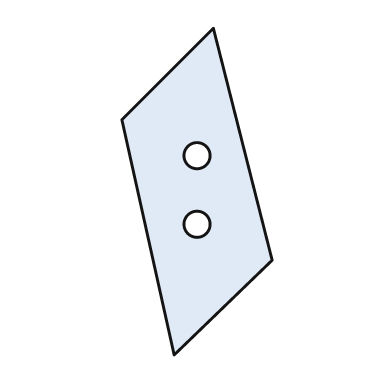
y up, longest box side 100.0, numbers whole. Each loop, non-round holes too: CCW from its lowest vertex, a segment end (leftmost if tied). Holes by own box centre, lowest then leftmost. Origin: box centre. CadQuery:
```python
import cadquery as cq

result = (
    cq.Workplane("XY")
    .moveTo(-7.0, -50.0)
    .lineTo(23.0, -21.0)
    .lineTo(5.0, 50.0)
    .lineTo(-23.0, 22.0)
    .close()
    .moveTo(0.0, -10.0)
    .circle(4.0)
    .moveTo(0.0, 11.0)
    .circle(4.0)
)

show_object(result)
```